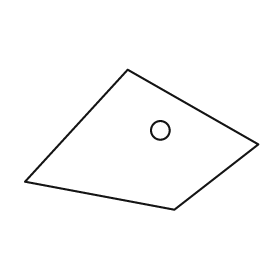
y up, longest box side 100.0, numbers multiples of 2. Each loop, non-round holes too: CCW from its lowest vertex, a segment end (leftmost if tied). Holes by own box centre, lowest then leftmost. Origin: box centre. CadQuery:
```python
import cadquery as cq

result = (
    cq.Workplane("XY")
    .moveTo(14.0, -30.0)
    .lineTo(50.0, -2.0)
    .lineTo(-6.0, 30.0)
    .lineTo(-50.0, -18.0)
    .close()
    .moveTo(8.0, 4.0)
    .circle(4.0)
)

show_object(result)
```